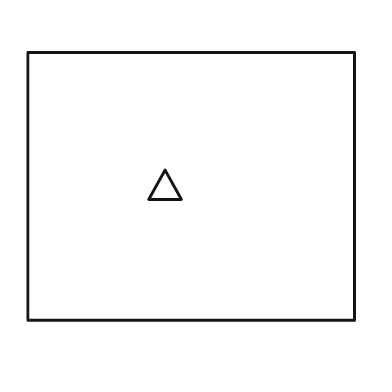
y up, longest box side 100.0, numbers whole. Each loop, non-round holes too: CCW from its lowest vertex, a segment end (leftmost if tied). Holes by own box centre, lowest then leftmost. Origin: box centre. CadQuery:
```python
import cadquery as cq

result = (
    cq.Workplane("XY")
    .moveTo(-50.0, -41.0)
    .lineTo(50.0, -41.0)
    .lineTo(50.0, 41.0)
    .lineTo(-50.0, 41.0)
    .close()
    .moveTo(-13.0, -4.0)
    .lineTo(-3.0, -4.0)
    .lineTo(-8.0, 5.0)
    .close()
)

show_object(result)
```